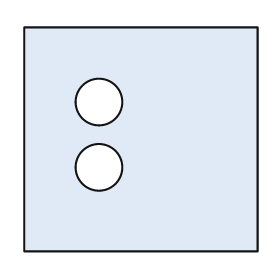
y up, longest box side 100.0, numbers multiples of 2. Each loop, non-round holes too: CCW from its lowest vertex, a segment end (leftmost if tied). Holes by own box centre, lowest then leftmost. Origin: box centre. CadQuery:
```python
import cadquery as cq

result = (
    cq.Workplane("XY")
    .moveTo(-50.0, -48.0)
    .lineTo(50.0, -48.0)
    .lineTo(50.0, 48.0)
    .lineTo(-50.0, 48.0)
    .close()
    .moveTo(-18.0, -12.0)
    .circle(10.0)
    .moveTo(-18.0, 16.0)
    .circle(10.0)
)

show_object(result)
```